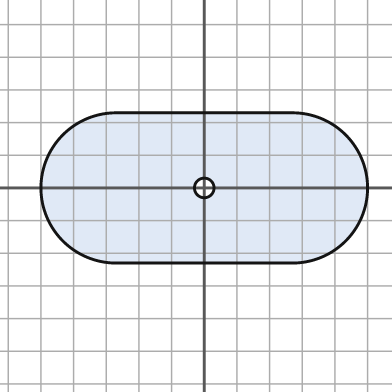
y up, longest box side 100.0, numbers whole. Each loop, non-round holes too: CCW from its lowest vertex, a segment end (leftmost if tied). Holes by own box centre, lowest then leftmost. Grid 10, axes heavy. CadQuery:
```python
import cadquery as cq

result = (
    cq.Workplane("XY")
    .moveTo(-27.0, -23.0)
    .lineTo(27.0, -23.0)
    .threePointArc((50.0, 0.0), (27.0, 23.0))
    .lineTo(-27.0, 23.0)
    .threePointArc((-50.0, 0.0), (-27.0, -23.0))
    .close()
    .moveTo(0.0, 0.0)
    .circle(3.0)
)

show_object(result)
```